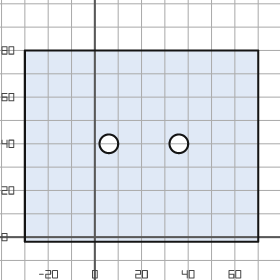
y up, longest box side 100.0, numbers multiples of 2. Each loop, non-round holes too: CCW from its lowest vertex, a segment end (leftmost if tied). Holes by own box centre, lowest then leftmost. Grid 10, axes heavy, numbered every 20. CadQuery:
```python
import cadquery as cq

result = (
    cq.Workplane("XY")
    .moveTo(-30.0, -2.0)
    .lineTo(70.0, -2.0)
    .lineTo(70.0, 80.0)
    .lineTo(-30.0, 80.0)
    .close()
    .moveTo(6.0, 40.0)
    .circle(4.0)
    .moveTo(36.0, 40.0)
    .circle(4.0)
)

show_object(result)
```